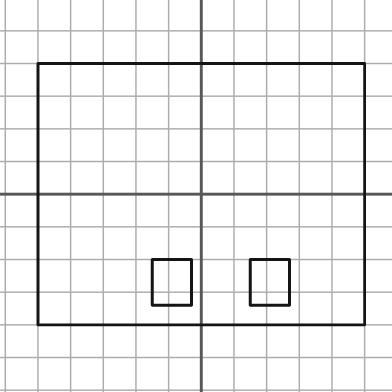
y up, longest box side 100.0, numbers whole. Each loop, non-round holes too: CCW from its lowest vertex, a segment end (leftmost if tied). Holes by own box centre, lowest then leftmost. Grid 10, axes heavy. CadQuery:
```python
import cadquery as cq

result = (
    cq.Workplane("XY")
    .moveTo(-50.0, -40.0)
    .lineTo(50.0, -40.0)
    .lineTo(50.0, 40.0)
    .lineTo(-50.0, 40.0)
    .close()
    .moveTo(-15.0, -34.0)
    .lineTo(-3.0, -34.0)
    .lineTo(-3.0, -20.0)
    .lineTo(-15.0, -20.0)
    .close()
    .moveTo(15.0, -34.0)
    .lineTo(27.0, -34.0)
    .lineTo(27.0, -20.0)
    .lineTo(15.0, -20.0)
    .close()
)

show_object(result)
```